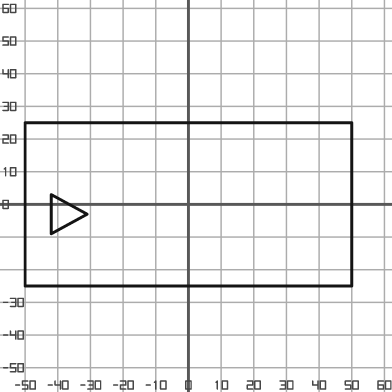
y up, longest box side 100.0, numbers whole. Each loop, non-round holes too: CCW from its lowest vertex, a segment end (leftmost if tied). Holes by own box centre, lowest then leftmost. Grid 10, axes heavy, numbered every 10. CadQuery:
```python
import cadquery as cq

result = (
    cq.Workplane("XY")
    .moveTo(-50.0, -25.0)
    .lineTo(50.0, -25.0)
    .lineTo(50.0, 25.0)
    .lineTo(-50.0, 25.0)
    .close()
    .moveTo(-42.0, -9.0)
    .lineTo(-31.0, -3.0)
    .lineTo(-42.0, 3.0)
    .close()
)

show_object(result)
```